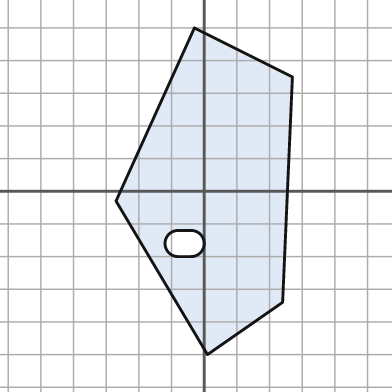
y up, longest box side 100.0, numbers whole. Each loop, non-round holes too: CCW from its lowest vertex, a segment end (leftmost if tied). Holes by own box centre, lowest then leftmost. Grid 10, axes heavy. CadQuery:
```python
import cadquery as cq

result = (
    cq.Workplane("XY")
    .moveTo(1.0, -50.0)
    .lineTo(24.0, -34.0)
    .lineTo(27.0, 35.0)
    .lineTo(-3.0, 50.0)
    .lineTo(-27.0, -3.0)
    .close()
    .moveTo(-8.0, -20.0)
    .lineTo(-4.0, -20.0)
    .threePointArc((0.0, -16.0), (-4.0, -12.0))
    .lineTo(-8.0, -12.0)
    .threePointArc((-12.0, -16.0), (-8.0, -20.0))
    .close()
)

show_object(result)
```